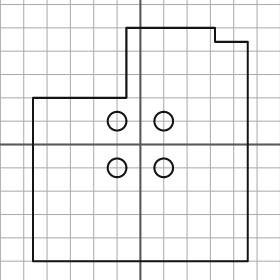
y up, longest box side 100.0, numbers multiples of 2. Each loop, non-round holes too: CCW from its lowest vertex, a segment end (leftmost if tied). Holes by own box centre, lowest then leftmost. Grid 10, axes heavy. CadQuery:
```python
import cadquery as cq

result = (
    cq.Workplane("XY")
    .moveTo(-46.0, -50.0)
    .lineTo(46.0, -50.0)
    .lineTo(46.0, 44.0)
    .lineTo(32.0, 44.0)
    .lineTo(32.0, 50.0)
    .lineTo(-6.0, 50.0)
    .lineTo(-6.0, 20.0)
    .lineTo(-46.0, 20.0)
    .close()
    .moveTo(-10.0, -10.0)
    .circle(4.0)
    .moveTo(10.0, -10.0)
    .circle(4.0)
    .moveTo(-10.0, 10.0)
    .circle(4.0)
    .moveTo(10.0, 10.0)
    .circle(4.0)
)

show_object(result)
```